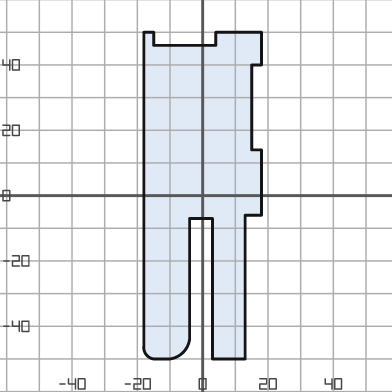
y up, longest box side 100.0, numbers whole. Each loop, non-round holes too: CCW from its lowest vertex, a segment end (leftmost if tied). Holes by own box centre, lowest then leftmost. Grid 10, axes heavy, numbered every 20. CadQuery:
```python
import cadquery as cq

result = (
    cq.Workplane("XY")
    .moveTo(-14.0, -50.0)
    .lineTo(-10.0, -50.0)
    .threePointArc((-6.0, -48.0), (-4.0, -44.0))
    .lineTo(-4.0, -7.0)
    .lineTo(3.0, -7.0)
    .lineTo(3.0, -50.0)
    .lineTo(13.0, -50.0)
    .lineTo(13.0, -6.0)
    .lineTo(18.0, -6.0)
    .lineTo(18.0, 14.0)
    .lineTo(15.0, 14.0)
    .lineTo(15.0, 40.0)
    .lineTo(18.0, 40.0)
    .lineTo(18.0, 50.0)
    .lineTo(4.0, 50.0)
    .lineTo(4.0, 46.0)
    .lineTo(-15.0, 46.0)
    .lineTo(-15.0, 50.0)
    .lineTo(-18.0, 50.0)
    .lineTo(-18.0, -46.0)
    .threePointArc((-17.0, -49.0), (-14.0, -50.0))
    .close()
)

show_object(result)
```